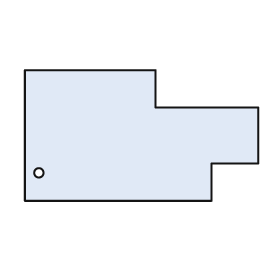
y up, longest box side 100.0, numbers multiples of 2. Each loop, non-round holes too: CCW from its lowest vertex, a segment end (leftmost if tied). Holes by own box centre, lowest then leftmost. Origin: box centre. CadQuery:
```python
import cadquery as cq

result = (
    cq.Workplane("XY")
    .moveTo(-50.0, -28.0)
    .lineTo(30.0, -28.0)
    .lineTo(30.0, -12.0)
    .lineTo(50.0, -12.0)
    .lineTo(50.0, 12.0)
    .lineTo(6.0, 12.0)
    .lineTo(6.0, 28.0)
    .lineTo(-50.0, 28.0)
    .close()
    .moveTo(-44.0, -16.0)
    .circle(2.0)
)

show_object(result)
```